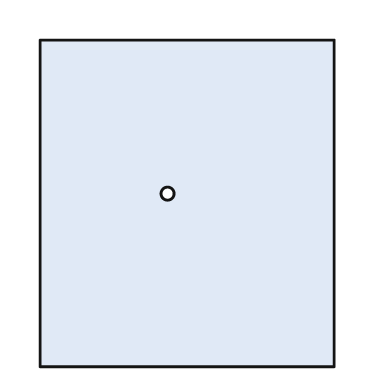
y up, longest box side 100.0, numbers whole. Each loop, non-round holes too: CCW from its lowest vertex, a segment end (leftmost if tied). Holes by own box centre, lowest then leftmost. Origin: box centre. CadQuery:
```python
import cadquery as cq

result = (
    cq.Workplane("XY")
    .moveTo(-45.0, -50.0)
    .lineTo(45.0, -50.0)
    .lineTo(45.0, 50.0)
    .lineTo(-45.0, 50.0)
    .close()
    .moveTo(-6.0, 3.0)
    .circle(2.0)
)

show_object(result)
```